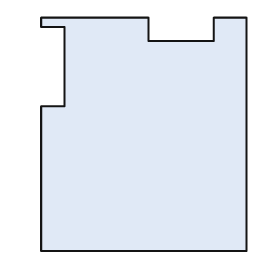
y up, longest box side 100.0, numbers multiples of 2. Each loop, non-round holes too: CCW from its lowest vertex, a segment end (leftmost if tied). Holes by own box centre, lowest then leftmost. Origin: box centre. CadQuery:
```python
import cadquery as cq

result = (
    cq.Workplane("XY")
    .moveTo(-44.0, -50.0)
    .lineTo(44.0, -50.0)
    .lineTo(44.0, 50.0)
    .lineTo(30.0, 50.0)
    .lineTo(30.0, 40.0)
    .lineTo(2.0, 40.0)
    .lineTo(2.0, 50.0)
    .lineTo(-44.0, 50.0)
    .lineTo(-44.0, 46.0)
    .lineTo(-34.0, 46.0)
    .lineTo(-34.0, 12.0)
    .lineTo(-44.0, 12.0)
    .close()
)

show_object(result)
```